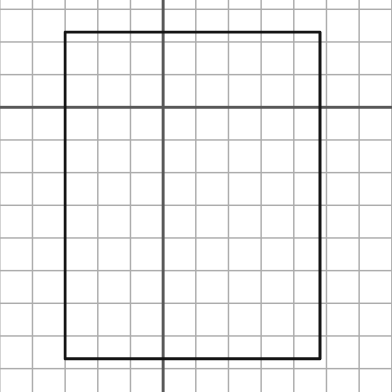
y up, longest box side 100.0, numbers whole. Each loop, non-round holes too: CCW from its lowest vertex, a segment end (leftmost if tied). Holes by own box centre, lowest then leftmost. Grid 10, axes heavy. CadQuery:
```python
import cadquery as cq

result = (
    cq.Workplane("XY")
    .moveTo(-30.0, -77.0)
    .lineTo(48.0, -77.0)
    .lineTo(48.0, 23.0)
    .lineTo(-30.0, 23.0)
    .close()
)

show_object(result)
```